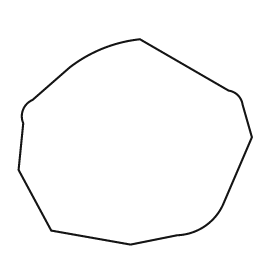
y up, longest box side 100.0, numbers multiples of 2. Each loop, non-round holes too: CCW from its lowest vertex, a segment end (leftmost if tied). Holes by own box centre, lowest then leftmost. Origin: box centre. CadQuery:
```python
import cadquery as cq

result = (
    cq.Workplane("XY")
    .moveTo(-2.0, -44.0)
    .lineTo(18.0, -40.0)
    .threePointArc((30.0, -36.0), (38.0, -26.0))
    .lineTo(50.0, 2.0)
    .lineTo(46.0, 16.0)
    .threePointArc((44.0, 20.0), (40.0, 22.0))
    .lineTo(2.0, 44.0)
    .threePointArc((-14.0, 40.0), (-28.0, 32.0))
    .lineTo(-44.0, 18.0)
    .threePointArc((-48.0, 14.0), (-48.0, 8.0))
    .lineTo(-50.0, -12.0)
    .lineTo(-36.0, -38.0)
    .close()
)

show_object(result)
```